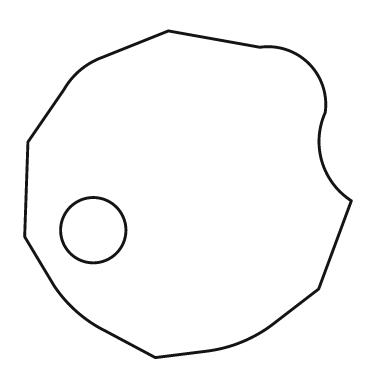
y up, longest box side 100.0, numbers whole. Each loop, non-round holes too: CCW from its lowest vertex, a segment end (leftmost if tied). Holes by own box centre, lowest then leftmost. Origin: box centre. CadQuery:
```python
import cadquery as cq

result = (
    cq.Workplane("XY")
    .moveTo(-10.0, -50.0)
    .lineTo(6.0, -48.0)
    .threePointArc((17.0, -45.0), (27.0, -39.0))
    .lineTo(40.0, -29.0)
    .lineTo(50.0, -2.0)
    .threePointArc((41.0, 10.0), (42.0, 25.0))
    .threePointArc((37.0, 40.0), (22.0, 45.0))
    .lineTo(-6.0, 50.0)
    .lineTo(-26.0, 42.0)
    .threePointArc((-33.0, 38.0), (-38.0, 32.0))
    .lineTo(-49.0, 16.0)
    .lineTo(-50.0, -13.0)
    .lineTo(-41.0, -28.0)
    .threePointArc((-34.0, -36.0), (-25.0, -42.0))
    .close()
    .moveTo(-29.0, -11.0)
    .circle(10.0)
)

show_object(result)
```